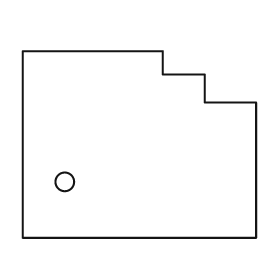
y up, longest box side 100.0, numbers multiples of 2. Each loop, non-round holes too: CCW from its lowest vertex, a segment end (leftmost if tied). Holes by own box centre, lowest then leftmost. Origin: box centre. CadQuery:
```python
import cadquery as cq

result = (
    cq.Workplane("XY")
    .moveTo(-50.0, -40.0)
    .lineTo(50.0, -40.0)
    .lineTo(50.0, 18.0)
    .lineTo(28.0, 18.0)
    .lineTo(28.0, 30.0)
    .lineTo(10.0, 30.0)
    .lineTo(10.0, 40.0)
    .lineTo(-50.0, 40.0)
    .close()
    .moveTo(-32.0, -16.0)
    .circle(4.0)
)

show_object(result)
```